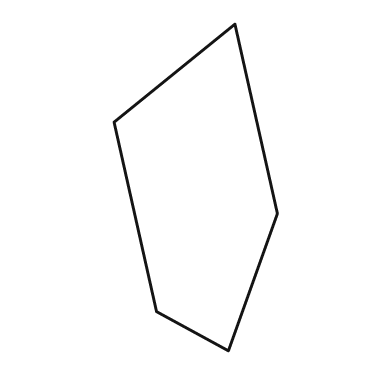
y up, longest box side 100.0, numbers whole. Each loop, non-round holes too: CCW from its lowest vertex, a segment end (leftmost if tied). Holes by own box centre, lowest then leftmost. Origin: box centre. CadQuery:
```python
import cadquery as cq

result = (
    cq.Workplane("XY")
    .moveTo(10.0, -50.0)
    .lineTo(25.0, -8.0)
    .lineTo(12.0, 50.0)
    .lineTo(-25.0, 20.0)
    .lineTo(-12.0, -38.0)
    .close()
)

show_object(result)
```